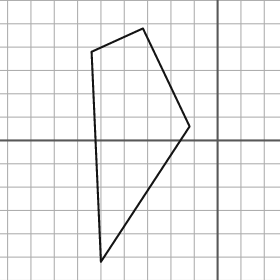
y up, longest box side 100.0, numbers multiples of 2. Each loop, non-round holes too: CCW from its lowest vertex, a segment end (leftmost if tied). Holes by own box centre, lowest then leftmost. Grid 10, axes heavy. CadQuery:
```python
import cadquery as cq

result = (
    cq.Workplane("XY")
    .moveTo(-50.0, -52.0)
    .lineTo(-12.0, 6.0)
    .lineTo(-32.0, 48.0)
    .lineTo(-54.0, 38.0)
    .close()
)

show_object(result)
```